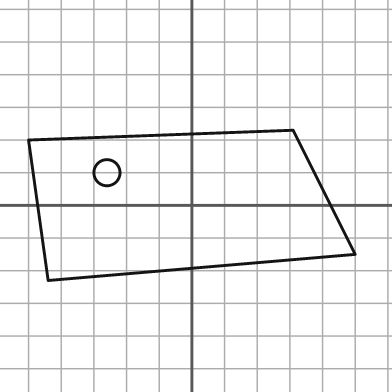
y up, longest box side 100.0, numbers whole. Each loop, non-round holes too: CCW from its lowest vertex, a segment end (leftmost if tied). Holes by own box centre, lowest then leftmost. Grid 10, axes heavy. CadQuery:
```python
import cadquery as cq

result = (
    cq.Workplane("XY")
    .moveTo(-44.0, -23.0)
    .lineTo(50.0, -15.0)
    .lineTo(31.0, 23.0)
    .lineTo(-50.0, 20.0)
    .close()
    .moveTo(-26.0, 10.0)
    .circle(4.0)
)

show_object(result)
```